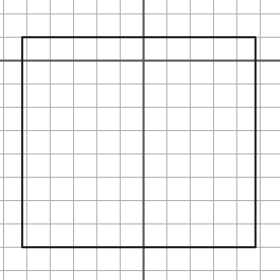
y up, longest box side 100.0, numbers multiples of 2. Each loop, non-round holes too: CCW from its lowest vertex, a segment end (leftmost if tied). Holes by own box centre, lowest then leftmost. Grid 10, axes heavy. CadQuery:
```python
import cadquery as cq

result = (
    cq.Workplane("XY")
    .moveTo(-52.0, -80.0)
    .lineTo(48.0, -80.0)
    .lineTo(48.0, 10.0)
    .lineTo(-52.0, 10.0)
    .close()
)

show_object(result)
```